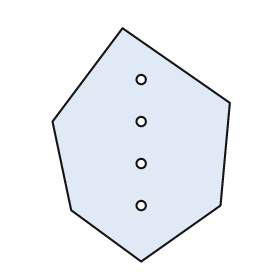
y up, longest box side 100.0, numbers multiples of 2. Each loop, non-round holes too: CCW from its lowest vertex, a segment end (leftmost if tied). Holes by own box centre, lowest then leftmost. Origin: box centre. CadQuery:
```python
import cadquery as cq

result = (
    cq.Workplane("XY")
    .moveTo(0.0, -50.0)
    .lineTo(34.0, -26.0)
    .lineTo(38.0, 18.0)
    .lineTo(-8.0, 50.0)
    .lineTo(-38.0, 10.0)
    .lineTo(-30.0, -28.0)
    .close()
    .moveTo(0.0, -26.0)
    .circle(2.0)
    .moveTo(0.0, -8.0)
    .circle(2.0)
    .moveTo(0.0, 10.0)
    .circle(2.0)
    .moveTo(0.0, 28.0)
    .circle(2.0)
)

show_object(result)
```